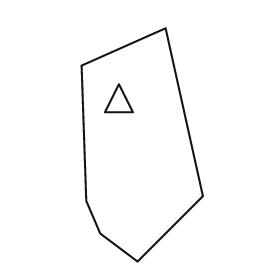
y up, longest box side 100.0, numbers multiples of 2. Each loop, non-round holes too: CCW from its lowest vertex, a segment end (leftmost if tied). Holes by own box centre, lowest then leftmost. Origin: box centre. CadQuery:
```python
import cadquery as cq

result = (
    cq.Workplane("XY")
    .moveTo(-2.0, -50.0)
    .lineTo(26.0, -22.0)
    .lineTo(10.0, 50.0)
    .lineTo(-26.0, 34.0)
    .lineTo(-24.0, -24.0)
    .lineTo(-18.0, -38.0)
    .close()
    .moveTo(-16.0, 14.0)
    .lineTo(-4.0, 14.0)
    .lineTo(-10.0, 26.0)
    .close()
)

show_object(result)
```